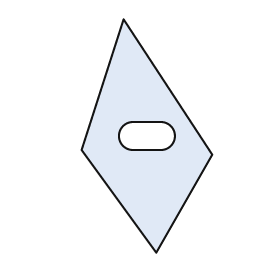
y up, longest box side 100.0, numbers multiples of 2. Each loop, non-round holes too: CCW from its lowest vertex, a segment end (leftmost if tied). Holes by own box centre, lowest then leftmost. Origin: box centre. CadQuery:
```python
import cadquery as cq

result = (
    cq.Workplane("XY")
    .moveTo(4.0, -50.0)
    .lineTo(28.0, -8.0)
    .lineTo(-10.0, 50.0)
    .lineTo(-28.0, -6.0)
    .close()
    .moveTo(-6.0, -6.0)
    .lineTo(6.0, -6.0)
    .threePointArc((12.0, 0.0), (6.0, 6.0))
    .lineTo(-6.0, 6.0)
    .threePointArc((-12.0, 0.0), (-6.0, -6.0))
    .close()
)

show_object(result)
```